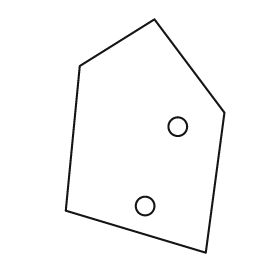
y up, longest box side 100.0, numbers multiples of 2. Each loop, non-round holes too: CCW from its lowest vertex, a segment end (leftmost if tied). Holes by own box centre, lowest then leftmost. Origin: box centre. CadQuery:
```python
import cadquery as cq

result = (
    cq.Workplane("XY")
    .moveTo(26.0, -50.0)
    .lineTo(34.0, 10.0)
    .lineTo(4.0, 50.0)
    .lineTo(-28.0, 30.0)
    .lineTo(-34.0, -32.0)
    .close()
    .moveTo(0.0, -30.0)
    .circle(4.0)
    .moveTo(14.0, 4.0)
    .circle(4.0)
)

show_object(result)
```